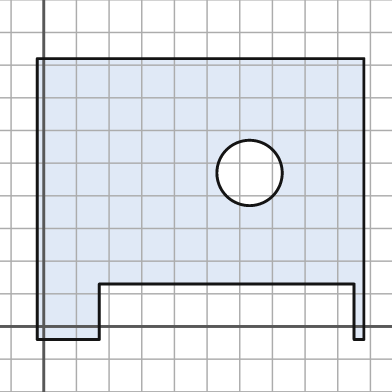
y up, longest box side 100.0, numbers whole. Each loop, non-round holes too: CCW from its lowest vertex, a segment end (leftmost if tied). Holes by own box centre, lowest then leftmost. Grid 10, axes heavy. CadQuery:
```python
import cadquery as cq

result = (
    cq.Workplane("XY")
    .moveTo(-2.0, -4.0)
    .lineTo(17.0, -4.0)
    .lineTo(17.0, 13.0)
    .lineTo(95.0, 13.0)
    .lineTo(95.0, -4.0)
    .lineTo(98.0, -4.0)
    .lineTo(98.0, 82.0)
    .lineTo(-2.0, 82.0)
    .close()
    .moveTo(63.0, 47.0)
    .circle(10.0)
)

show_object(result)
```